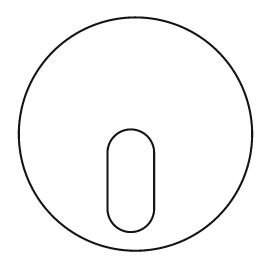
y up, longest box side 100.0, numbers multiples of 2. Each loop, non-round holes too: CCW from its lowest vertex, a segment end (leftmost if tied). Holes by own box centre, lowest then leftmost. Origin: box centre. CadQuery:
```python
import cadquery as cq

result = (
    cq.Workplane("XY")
    .moveTo(0.0, 0.0)
    .circle(50.0)
    .moveTo(-12.0, -32.0)
    .threePointArc((-2.0, -42.0), (8.0, -32.0))
    .lineTo(8.0, -8.0)
    .threePointArc((-2.0, 2.0), (-12.0, -8.0))
    .close()
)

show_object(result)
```